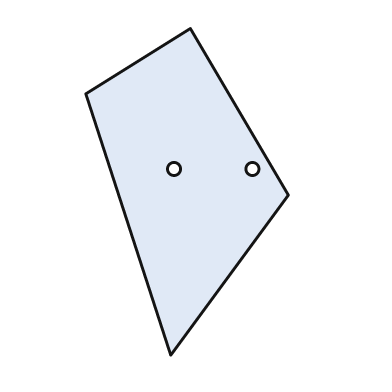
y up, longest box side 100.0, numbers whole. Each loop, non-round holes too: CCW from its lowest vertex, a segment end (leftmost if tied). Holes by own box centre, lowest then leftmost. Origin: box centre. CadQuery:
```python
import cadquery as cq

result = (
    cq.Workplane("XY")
    .moveTo(-5.0, -50.0)
    .lineTo(31.0, -1.0)
    .lineTo(1.0, 50.0)
    .lineTo(-31.0, 30.0)
    .close()
    .moveTo(-4.0, 7.0)
    .circle(2.0)
    .moveTo(20.0, 7.0)
    .circle(2.0)
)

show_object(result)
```